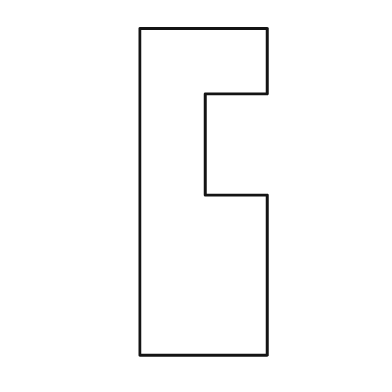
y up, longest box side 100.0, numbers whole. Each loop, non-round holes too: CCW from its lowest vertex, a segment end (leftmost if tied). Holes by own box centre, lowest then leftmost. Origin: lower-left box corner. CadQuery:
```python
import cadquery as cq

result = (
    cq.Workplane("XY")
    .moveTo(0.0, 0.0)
    .lineTo(39.0, 0.0)
    .lineTo(39.0, 49.0)
    .lineTo(20.0, 49.0)
    .lineTo(20.0, 80.0)
    .lineTo(39.0, 80.0)
    .lineTo(39.0, 100.0)
    .lineTo(0.0, 100.0)
    .close()
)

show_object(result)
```